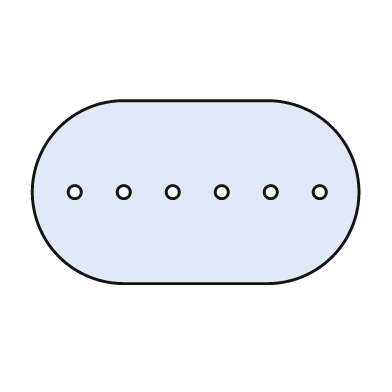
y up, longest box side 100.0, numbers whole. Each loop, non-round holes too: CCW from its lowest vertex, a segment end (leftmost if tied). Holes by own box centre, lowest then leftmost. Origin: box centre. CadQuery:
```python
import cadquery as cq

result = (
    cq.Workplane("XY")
    .moveTo(-22.0, -28.0)
    .lineTo(22.0, -28.0)
    .threePointArc((50.0, 0.0), (22.0, 28.0))
    .lineTo(-22.0, 28.0)
    .threePointArc((-50.0, 0.0), (-22.0, -28.0))
    .close()
    .moveTo(-37.0, 0.0)
    .circle(2.0)
    .moveTo(-22.0, 0.0)
    .circle(2.0)
    .moveTo(-7.0, 0.0)
    .circle(2.0)
    .moveTo(8.0, 0.0)
    .circle(2.0)
    .moveTo(23.0, 0.0)
    .circle(2.0)
    .moveTo(38.0, 0.0)
    .circle(2.0)
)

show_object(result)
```